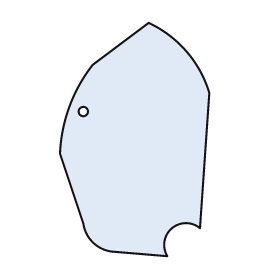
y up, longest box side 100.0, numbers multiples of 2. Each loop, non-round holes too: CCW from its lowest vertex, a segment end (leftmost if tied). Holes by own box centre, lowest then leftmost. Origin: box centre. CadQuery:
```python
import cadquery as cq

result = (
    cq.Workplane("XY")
    .moveTo(14.0, -50.0)
    .threePointArc((16.0, -38.0), (28.0, -38.0))
    .lineTo(32.0, 20.0)
    .threePointArc((22.0, 38.0), (6.0, 50.0))
    .lineTo(-18.0, 32.0)
    .threePointArc((-28.0, 14.0), (-32.0, -6.0))
    .lineTo(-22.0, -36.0)
    .threePointArc((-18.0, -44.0), (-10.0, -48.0))
    .close()
    .moveTo(-22.0, 12.0)
    .circle(2.0)
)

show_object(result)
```